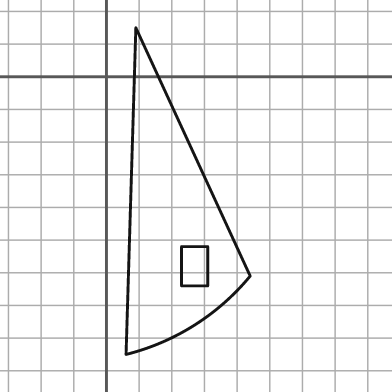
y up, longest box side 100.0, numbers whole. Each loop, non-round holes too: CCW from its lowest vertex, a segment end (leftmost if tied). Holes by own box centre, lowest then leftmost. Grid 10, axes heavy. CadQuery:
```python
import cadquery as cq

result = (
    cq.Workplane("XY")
    .moveTo(6.0, -85.0)
    .threePointArc((27.0, -76.0), (44.0, -61.0))
    .lineTo(9.0, 15.0)
    .close()
    .moveTo(23.0, -64.0)
    .lineTo(31.0, -64.0)
    .lineTo(31.0, -52.0)
    .lineTo(23.0, -52.0)
    .close()
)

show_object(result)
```